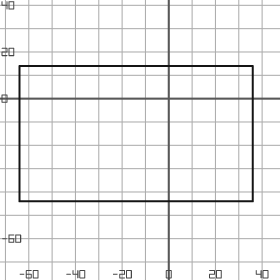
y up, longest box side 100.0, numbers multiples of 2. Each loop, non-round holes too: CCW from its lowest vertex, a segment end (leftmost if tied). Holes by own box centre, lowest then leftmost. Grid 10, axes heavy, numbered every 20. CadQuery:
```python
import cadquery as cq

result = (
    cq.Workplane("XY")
    .moveTo(-64.0, -44.0)
    .lineTo(36.0, -44.0)
    .lineTo(36.0, 14.0)
    .lineTo(-64.0, 14.0)
    .close()
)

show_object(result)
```